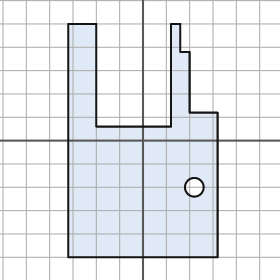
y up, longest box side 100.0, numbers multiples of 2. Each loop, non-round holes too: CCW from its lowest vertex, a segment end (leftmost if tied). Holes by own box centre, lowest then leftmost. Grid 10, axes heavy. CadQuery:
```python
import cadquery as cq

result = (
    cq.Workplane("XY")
    .moveTo(-32.0, -50.0)
    .lineTo(32.0, -50.0)
    .lineTo(32.0, 12.0)
    .lineTo(20.0, 12.0)
    .lineTo(20.0, 38.0)
    .lineTo(16.0, 38.0)
    .lineTo(16.0, 50.0)
    .lineTo(12.0, 50.0)
    .lineTo(12.0, 6.0)
    .lineTo(-20.0, 6.0)
    .lineTo(-20.0, 50.0)
    .lineTo(-32.0, 50.0)
    .close()
    .moveTo(22.0, -20.0)
    .circle(4.0)
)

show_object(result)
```